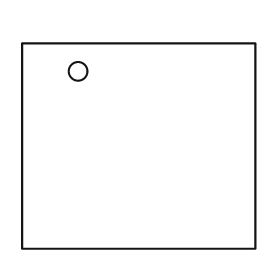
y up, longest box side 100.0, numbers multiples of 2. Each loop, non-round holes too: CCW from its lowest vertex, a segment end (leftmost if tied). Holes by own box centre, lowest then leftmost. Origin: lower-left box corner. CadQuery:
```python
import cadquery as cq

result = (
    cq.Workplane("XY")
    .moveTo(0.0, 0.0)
    .lineTo(100.0, 0.0)
    .lineTo(100.0, 88.0)
    .lineTo(0.0, 88.0)
    .close()
    .moveTo(24.0, 76.0)
    .circle(4.0)
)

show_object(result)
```